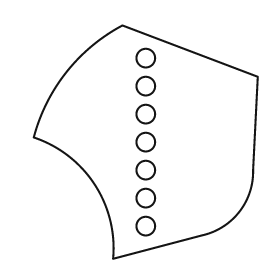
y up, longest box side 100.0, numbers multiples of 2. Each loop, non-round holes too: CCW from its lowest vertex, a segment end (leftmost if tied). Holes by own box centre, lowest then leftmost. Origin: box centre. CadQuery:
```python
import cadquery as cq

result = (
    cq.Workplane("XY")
    .moveTo(-14.0, -50.0)
    .lineTo(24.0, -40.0)
    .threePointArc((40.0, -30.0), (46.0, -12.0))
    .lineTo(48.0, 28.0)
    .lineTo(-10.0, 50.0)
    .threePointArc((-34.0, 30.0), (-48.0, 2.0))
    .threePointArc((-22.0, -18.0), (-14.0, -50.0))
    .close()
    .moveTo(0.0, -36.0)
    .circle(4.0)
    .moveTo(0.0, -24.0)
    .circle(4.0)
    .moveTo(0.0, -12.0)
    .circle(4.0)
    .moveTo(0.0, 0.0)
    .circle(4.0)
    .moveTo(0.0, 12.0)
    .circle(4.0)
    .moveTo(0.0, 24.0)
    .circle(4.0)
    .moveTo(0.0, 36.0)
    .circle(4.0)
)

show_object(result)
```